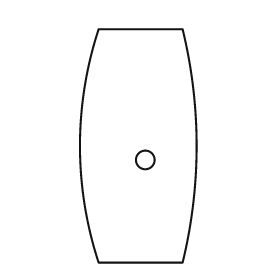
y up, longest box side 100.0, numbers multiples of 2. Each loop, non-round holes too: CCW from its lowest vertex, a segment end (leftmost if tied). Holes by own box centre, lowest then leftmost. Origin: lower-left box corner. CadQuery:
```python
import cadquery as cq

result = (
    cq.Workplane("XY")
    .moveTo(8.0, 0.0)
    .lineTo(44.0, 0.0)
    .threePointArc((50.0, 50.0), (44.0, 100.0))
    .lineTo(8.0, 100.0)
    .threePointArc((0.0, 50.0), (8.0, 0.0))
    .close()
    .moveTo(28.0, 44.0)
    .circle(4.0)
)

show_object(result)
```